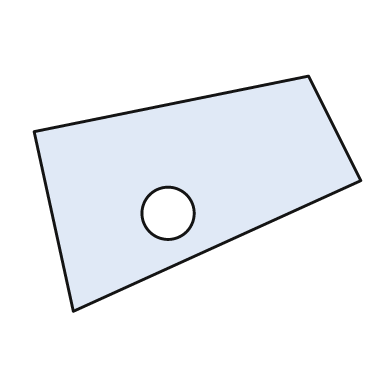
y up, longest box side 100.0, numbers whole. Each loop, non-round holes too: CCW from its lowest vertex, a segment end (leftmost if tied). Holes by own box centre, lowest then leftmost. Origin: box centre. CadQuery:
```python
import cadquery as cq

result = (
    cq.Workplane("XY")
    .moveTo(-38.0, -36.0)
    .lineTo(50.0, 4.0)
    .lineTo(34.0, 36.0)
    .lineTo(-50.0, 19.0)
    .close()
    .moveTo(-9.0, -6.0)
    .circle(8.0)
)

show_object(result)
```